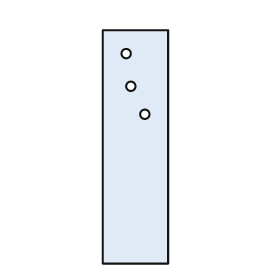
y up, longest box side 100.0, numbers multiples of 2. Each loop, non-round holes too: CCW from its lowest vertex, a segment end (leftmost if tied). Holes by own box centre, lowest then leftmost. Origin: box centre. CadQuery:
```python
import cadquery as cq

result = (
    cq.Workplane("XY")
    .moveTo(-14.0, -50.0)
    .lineTo(14.0, -50.0)
    .lineTo(14.0, 50.0)
    .lineTo(-14.0, 50.0)
    .close()
    .moveTo(4.0, 14.0)
    .circle(2.0)
    .moveTo(-2.0, 26.0)
    .circle(2.0)
    .moveTo(-4.0, 40.0)
    .circle(2.0)
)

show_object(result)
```